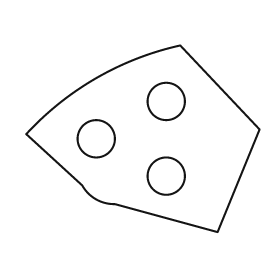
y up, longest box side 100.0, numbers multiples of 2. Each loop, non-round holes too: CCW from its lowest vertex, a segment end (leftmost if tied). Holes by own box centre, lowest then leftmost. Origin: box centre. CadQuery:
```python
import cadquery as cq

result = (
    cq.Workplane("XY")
    .moveTo(32.0, -40.0)
    .lineTo(50.0, 4.0)
    .lineTo(16.0, 40.0)
    .threePointArc((-20.0, 26.0), (-50.0, 2.0))
    .lineTo(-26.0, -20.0)
    .threePointArc((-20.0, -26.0), (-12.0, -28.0))
    .close()
    .moveTo(10.0, -16.0)
    .circle(8.0)
    .moveTo(-20.0, 0.0)
    .circle(8.0)
    .moveTo(10.0, 16.0)
    .circle(8.0)
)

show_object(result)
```